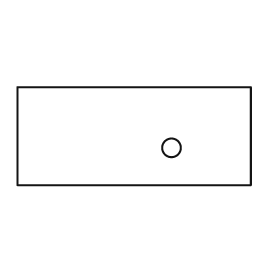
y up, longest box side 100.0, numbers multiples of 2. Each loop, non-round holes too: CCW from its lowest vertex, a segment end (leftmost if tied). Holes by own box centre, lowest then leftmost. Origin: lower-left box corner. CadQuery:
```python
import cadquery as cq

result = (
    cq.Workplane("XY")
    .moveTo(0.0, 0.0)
    .lineTo(100.0, 0.0)
    .lineTo(100.0, 42.0)
    .lineTo(0.0, 42.0)
    .close()
    .moveTo(66.0, 16.0)
    .circle(4.0)
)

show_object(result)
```